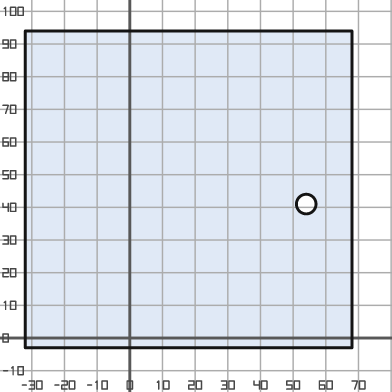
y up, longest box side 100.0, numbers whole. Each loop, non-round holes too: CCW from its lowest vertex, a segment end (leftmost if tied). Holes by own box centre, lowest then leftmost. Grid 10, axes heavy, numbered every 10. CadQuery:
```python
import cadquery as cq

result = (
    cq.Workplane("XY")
    .moveTo(-32.0, -3.0)
    .lineTo(68.0, -3.0)
    .lineTo(68.0, 94.0)
    .lineTo(-32.0, 94.0)
    .close()
    .moveTo(54.0, 41.0)
    .circle(3.0)
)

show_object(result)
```